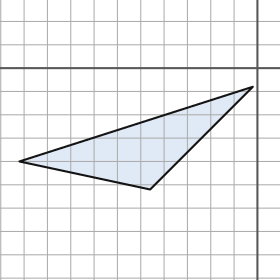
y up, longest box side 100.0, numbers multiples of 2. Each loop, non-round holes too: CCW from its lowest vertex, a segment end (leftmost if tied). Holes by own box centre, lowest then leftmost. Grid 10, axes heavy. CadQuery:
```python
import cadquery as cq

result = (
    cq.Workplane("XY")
    .moveTo(-46.0, -52.0)
    .lineTo(-2.0, -8.0)
    .lineTo(-102.0, -40.0)
    .close()
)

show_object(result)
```